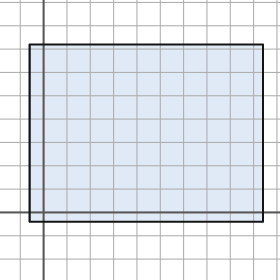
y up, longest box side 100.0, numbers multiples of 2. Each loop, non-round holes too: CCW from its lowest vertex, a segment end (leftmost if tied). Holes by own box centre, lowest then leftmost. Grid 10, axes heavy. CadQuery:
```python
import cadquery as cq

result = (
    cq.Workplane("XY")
    .moveTo(-6.0, -4.0)
    .lineTo(94.0, -4.0)
    .lineTo(94.0, 72.0)
    .lineTo(-6.0, 72.0)
    .close()
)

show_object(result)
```